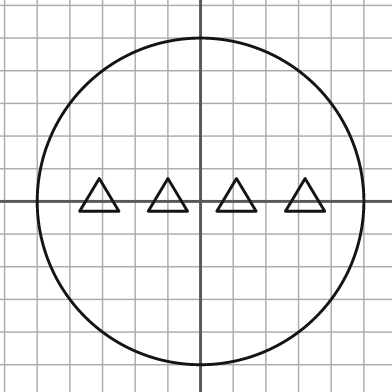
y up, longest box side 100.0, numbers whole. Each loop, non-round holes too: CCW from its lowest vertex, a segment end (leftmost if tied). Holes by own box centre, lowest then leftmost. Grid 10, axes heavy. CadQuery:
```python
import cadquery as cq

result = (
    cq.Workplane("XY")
    .moveTo(0.0, 0.0)
    .circle(50.0)
    .moveTo(-37.0, -3.0)
    .lineTo(-25.0, -3.0)
    .lineTo(-31.0, 7.0)
    .close()
    .moveTo(-16.0, -3.0)
    .lineTo(-4.0, -3.0)
    .lineTo(-10.0, 7.0)
    .close()
    .moveTo(5.0, -3.0)
    .lineTo(17.0, -3.0)
    .lineTo(11.0, 7.0)
    .close()
    .moveTo(26.0, -3.0)
    .lineTo(38.0, -3.0)
    .lineTo(32.0, 7.0)
    .close()
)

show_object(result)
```